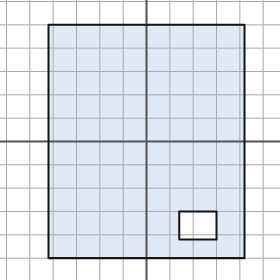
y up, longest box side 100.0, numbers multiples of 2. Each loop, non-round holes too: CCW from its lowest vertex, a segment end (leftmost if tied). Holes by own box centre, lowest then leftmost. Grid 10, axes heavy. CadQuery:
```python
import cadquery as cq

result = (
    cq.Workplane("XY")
    .moveTo(-42.0, -50.0)
    .lineTo(42.0, -50.0)
    .lineTo(42.0, 50.0)
    .lineTo(-42.0, 50.0)
    .close()
    .moveTo(14.0, -42.0)
    .lineTo(30.0, -42.0)
    .lineTo(30.0, -30.0)
    .lineTo(14.0, -30.0)
    .close()
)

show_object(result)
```